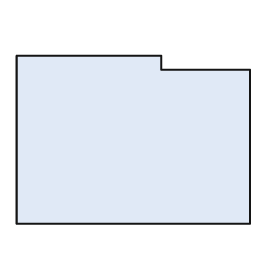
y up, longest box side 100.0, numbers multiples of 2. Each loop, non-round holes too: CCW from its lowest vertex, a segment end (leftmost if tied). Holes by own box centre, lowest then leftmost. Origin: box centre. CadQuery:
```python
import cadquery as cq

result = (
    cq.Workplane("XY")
    .moveTo(-50.0, -36.0)
    .lineTo(50.0, -36.0)
    .lineTo(50.0, 30.0)
    .lineTo(12.0, 30.0)
    .lineTo(12.0, 36.0)
    .lineTo(-50.0, 36.0)
    .close()
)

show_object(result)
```